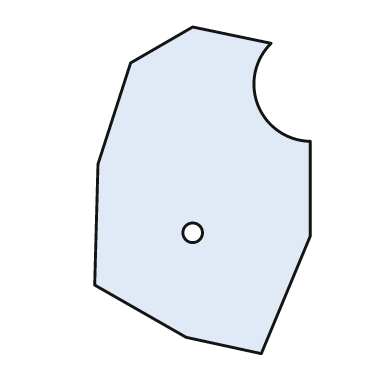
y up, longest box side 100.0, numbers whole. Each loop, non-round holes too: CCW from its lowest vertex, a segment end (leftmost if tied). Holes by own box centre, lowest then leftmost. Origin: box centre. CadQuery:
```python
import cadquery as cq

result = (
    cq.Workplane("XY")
    .moveTo(18.0, -50.0)
    .lineTo(33.0, -14.0)
    .lineTo(33.0, 15.0)
    .threePointArc((17.0, 26.0), (21.0, 45.0))
    .lineTo(-3.0, 50.0)
    .lineTo(-22.0, 39.0)
    .lineTo(-32.0, 8.0)
    .lineTo(-33.0, -29.0)
    .lineTo(-5.0, -45.0)
    .close()
    .moveTo(-3.0, -13.0)
    .circle(3.0)
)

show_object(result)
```